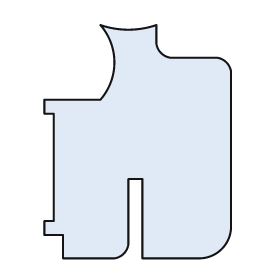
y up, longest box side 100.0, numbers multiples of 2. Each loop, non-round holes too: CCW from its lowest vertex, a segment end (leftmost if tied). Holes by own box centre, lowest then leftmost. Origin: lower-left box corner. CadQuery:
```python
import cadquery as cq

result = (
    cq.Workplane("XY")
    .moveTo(8.0, 0.0)
    .lineTo(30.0, 0.0)
    .threePointArc((34.0, 2.0), (36.0, 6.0))
    .lineTo(36.0, 34.0)
    .lineTo(42.0, 34.0)
    .lineTo(42.0, 0.0)
    .lineTo(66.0, 0.0)
    .threePointArc((76.0, 4.0), (80.0, 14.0))
    .lineTo(80.0, 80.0)
    .threePointArc((78.0, 84.0), (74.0, 86.0))
    .lineTo(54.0, 86.0)
    .threePointArc((50.0, 88.0), (48.0, 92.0))
    .lineTo(48.0, 100.0)
    .threePointArc((36.0, 98.0), (24.0, 100.0))
    .threePointArc((30.0, 84.0), (24.0, 68.0))
    .lineTo(0.0, 68.0)
    .lineTo(0.0, 62.0)
    .lineTo(4.0, 62.0)
    .lineTo(4.0, 16.0)
    .lineTo(0.0, 16.0)
    .lineTo(0.0, 10.0)
    .lineTo(8.0, 10.0)
    .close()
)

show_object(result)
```